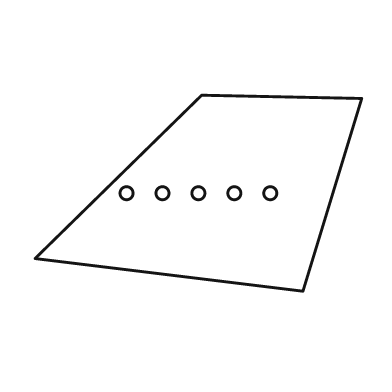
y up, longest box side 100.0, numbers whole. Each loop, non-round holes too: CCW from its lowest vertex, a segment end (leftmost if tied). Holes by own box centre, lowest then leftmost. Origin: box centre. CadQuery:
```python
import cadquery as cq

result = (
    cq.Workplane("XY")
    .moveTo(32.0, -30.0)
    .lineTo(50.0, 29.0)
    .lineTo(1.0, 30.0)
    .lineTo(-50.0, -20.0)
    .close()
    .moveTo(-22.0, 0.0)
    .circle(2.0)
    .moveTo(-11.0, 0.0)
    .circle(2.0)
    .moveTo(0.0, 0.0)
    .circle(2.0)
    .moveTo(11.0, 0.0)
    .circle(2.0)
    .moveTo(22.0, 0.0)
    .circle(2.0)
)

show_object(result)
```